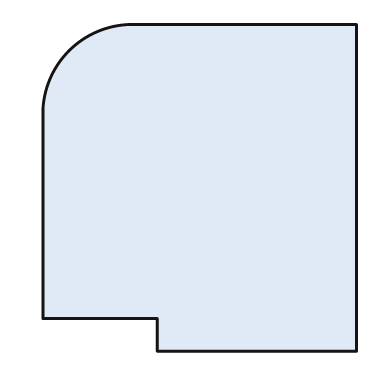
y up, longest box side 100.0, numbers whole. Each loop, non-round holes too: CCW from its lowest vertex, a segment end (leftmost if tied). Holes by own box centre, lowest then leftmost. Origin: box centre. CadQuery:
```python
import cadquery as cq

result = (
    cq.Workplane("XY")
    .moveTo(-13.0, -50.0)
    .lineTo(48.0, -50.0)
    .lineTo(48.0, 50.0)
    .lineTo(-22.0, 50.0)
    .threePointArc((-40.0, 42.0), (-48.0, 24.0))
    .lineTo(-48.0, -40.0)
    .lineTo(-13.0, -40.0)
    .close()
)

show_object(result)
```